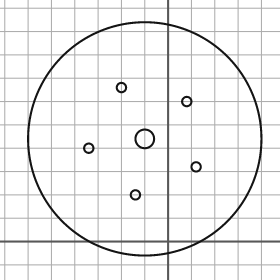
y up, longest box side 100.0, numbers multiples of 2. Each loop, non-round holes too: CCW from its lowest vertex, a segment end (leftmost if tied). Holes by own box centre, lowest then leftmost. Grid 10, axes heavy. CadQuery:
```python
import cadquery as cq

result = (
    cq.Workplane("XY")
    .moveTo(-10.0, 44.0)
    .circle(50.0)
    .moveTo(-14.0, 20.0)
    .circle(2.0)
    .moveTo(12.0, 32.0)
    .circle(2.0)
    .moveTo(-34.0, 40.0)
    .circle(2.0)
    .moveTo(-10.0, 44.0)
    .circle(4.0)
    .moveTo(8.0, 60.0)
    .circle(2.0)
    .moveTo(-20.0, 66.0)
    .circle(2.0)
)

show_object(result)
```